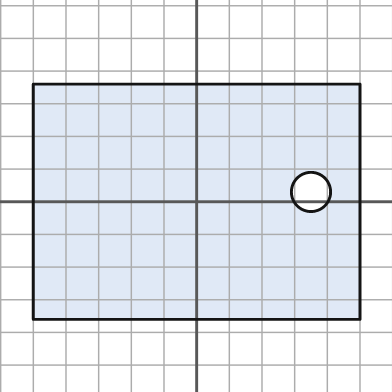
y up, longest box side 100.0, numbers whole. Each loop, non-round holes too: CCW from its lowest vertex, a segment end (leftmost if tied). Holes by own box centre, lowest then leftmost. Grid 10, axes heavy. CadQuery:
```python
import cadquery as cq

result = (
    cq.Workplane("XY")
    .moveTo(-50.0, -36.0)
    .lineTo(50.0, -36.0)
    .lineTo(50.0, 36.0)
    .lineTo(-50.0, 36.0)
    .close()
    .moveTo(35.0, 3.0)
    .circle(6.0)
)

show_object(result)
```